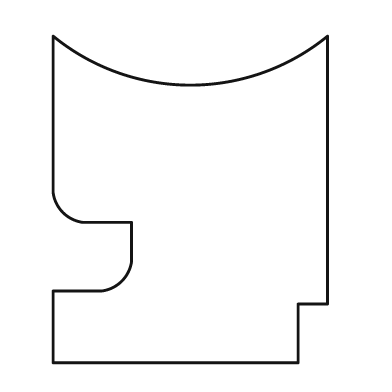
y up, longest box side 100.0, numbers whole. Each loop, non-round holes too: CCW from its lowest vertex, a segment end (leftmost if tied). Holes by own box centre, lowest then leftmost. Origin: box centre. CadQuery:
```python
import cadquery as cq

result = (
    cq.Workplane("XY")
    .moveTo(-42.0, -50.0)
    .lineTo(33.0, -50.0)
    .lineTo(33.0, -32.0)
    .lineTo(42.0, -32.0)
    .lineTo(42.0, 50.0)
    .threePointArc((0.0, 35.0), (-42.0, 50.0))
    .lineTo(-42.0, 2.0)
    .threePointArc((-39.0, -4.0), (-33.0, -7.0))
    .lineTo(-18.0, -7.0)
    .lineTo(-18.0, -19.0)
    .threePointArc((-21.0, -25.0), (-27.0, -28.0))
    .lineTo(-42.0, -28.0)
    .close()
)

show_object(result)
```